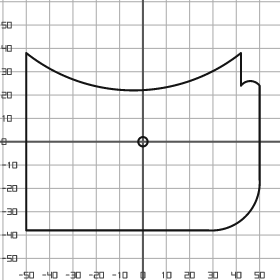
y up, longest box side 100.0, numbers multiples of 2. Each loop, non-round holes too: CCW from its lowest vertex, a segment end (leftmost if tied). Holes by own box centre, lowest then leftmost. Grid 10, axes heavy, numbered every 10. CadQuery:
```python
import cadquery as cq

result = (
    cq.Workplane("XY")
    .moveTo(-50.0, -38.0)
    .lineTo(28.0, -38.0)
    .threePointArc((44.0, -32.0), (50.0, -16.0))
    .lineTo(50.0, 24.0)
    .threePointArc((46.0, 26.0), (42.0, 24.0))
    .lineTo(42.0, 38.0)
    .threePointArc((-4.0, 22.0), (-50.0, 38.0))
    .close()
    .moveTo(0.0, 0.0)
    .circle(2.0)
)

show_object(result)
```